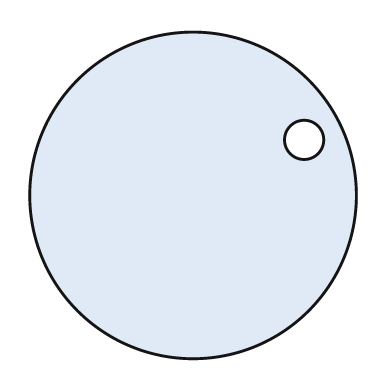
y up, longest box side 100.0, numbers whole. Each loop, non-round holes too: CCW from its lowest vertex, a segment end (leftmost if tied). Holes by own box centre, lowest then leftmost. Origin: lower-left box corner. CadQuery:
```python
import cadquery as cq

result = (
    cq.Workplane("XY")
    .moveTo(50.0, 50.0)
    .circle(50.0)
    .moveTo(84.0, 67.0)
    .circle(6.0)
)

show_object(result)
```